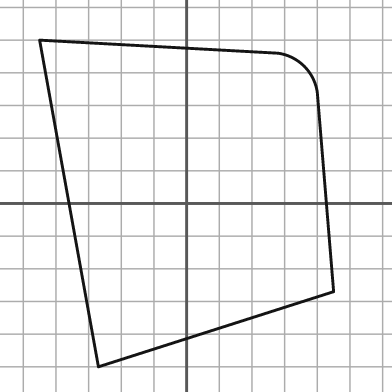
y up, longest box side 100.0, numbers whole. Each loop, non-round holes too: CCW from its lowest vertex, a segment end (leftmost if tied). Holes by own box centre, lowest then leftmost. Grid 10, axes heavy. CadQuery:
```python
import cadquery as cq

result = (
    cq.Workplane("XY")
    .moveTo(-27.0, -50.0)
    .lineTo(45.0, -27.0)
    .lineTo(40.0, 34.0)
    .threePointArc((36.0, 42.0), (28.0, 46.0))
    .lineTo(-45.0, 50.0)
    .close()
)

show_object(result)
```